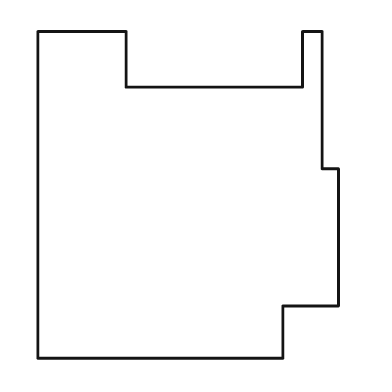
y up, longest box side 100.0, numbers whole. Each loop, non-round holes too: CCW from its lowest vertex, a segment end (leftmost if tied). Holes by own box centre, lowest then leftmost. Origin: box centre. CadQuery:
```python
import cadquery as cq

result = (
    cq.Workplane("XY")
    .moveTo(-46.0, -50.0)
    .lineTo(29.0, -50.0)
    .lineTo(29.0, -34.0)
    .lineTo(46.0, -34.0)
    .lineTo(46.0, 8.0)
    .lineTo(41.0, 8.0)
    .lineTo(41.0, 50.0)
    .lineTo(35.0, 50.0)
    .lineTo(35.0, 33.0)
    .lineTo(-19.0, 33.0)
    .lineTo(-19.0, 50.0)
    .lineTo(-46.0, 50.0)
    .close()
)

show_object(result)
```